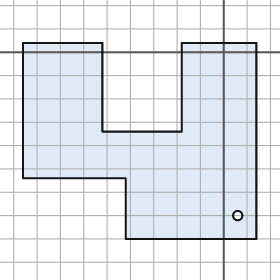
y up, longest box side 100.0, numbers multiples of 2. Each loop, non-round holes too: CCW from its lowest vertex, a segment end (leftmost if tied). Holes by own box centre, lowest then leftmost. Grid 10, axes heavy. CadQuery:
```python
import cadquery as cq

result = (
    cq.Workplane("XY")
    .moveTo(-42.0, -80.0)
    .lineTo(14.0, -80.0)
    .lineTo(14.0, 4.0)
    .lineTo(-18.0, 4.0)
    .lineTo(-18.0, -34.0)
    .lineTo(-52.0, -34.0)
    .lineTo(-52.0, 4.0)
    .lineTo(-86.0, 4.0)
    .lineTo(-86.0, -54.0)
    .lineTo(-42.0, -54.0)
    .close()
    .moveTo(6.0, -70.0)
    .circle(2.0)
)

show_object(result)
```